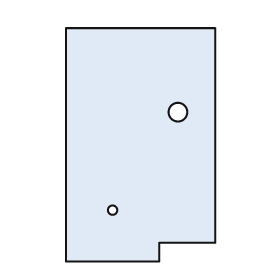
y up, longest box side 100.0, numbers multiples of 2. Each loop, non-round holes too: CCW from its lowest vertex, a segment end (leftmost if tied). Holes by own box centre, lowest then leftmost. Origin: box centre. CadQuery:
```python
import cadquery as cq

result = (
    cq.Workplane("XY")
    .moveTo(-32.0, -50.0)
    .lineTo(8.0, -50.0)
    .lineTo(8.0, -42.0)
    .lineTo(32.0, -42.0)
    .lineTo(32.0, 50.0)
    .lineTo(-32.0, 50.0)
    .close()
    .moveTo(-12.0, -28.0)
    .circle(2.0)
    .moveTo(16.0, 14.0)
    .circle(4.0)
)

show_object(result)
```